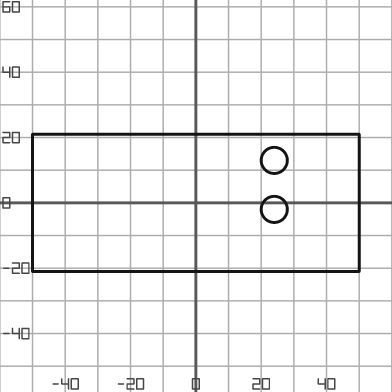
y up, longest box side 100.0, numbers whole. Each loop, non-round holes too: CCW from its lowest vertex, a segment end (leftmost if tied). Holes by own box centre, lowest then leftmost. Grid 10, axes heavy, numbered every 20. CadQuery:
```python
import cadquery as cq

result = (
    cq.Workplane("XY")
    .moveTo(-50.0, -21.0)
    .lineTo(50.0, -21.0)
    .lineTo(50.0, 21.0)
    .lineTo(-50.0, 21.0)
    .close()
    .moveTo(24.0, -2.0)
    .circle(4.0)
    .moveTo(24.0, 13.0)
    .circle(4.0)
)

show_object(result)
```